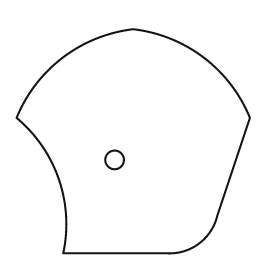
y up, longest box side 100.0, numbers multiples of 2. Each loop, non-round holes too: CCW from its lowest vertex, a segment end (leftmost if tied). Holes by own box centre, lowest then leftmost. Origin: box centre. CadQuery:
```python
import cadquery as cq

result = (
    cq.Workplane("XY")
    .moveTo(-30.0, -48.0)
    .lineTo(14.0, -48.0)
    .threePointArc((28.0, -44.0), (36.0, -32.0))
    .lineTo(50.0, 10.0)
    .threePointArc((30.0, 36.0), (0.0, 48.0))
    .threePointArc((-30.0, 36.0), (-50.0, 10.0))
    .threePointArc((-32.0, -16.0), (-30.0, -48.0))
    .close()
    .moveTo(-8.0, -8.0)
    .circle(4.0)
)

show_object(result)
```